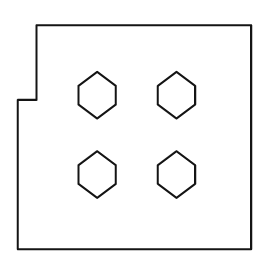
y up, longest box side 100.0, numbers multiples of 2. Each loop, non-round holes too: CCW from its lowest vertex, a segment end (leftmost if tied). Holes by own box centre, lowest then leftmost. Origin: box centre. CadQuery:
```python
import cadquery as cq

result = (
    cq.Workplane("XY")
    .moveTo(-50.0, -48.0)
    .lineTo(50.0, -48.0)
    .lineTo(50.0, 48.0)
    .lineTo(-42.0, 48.0)
    .lineTo(-42.0, 16.0)
    .lineTo(-50.0, 16.0)
    .close()
    .moveTo(-16.0, -26.0)
    .lineTo(-8.0, -20.0)
    .lineTo(-8.0, -12.0)
    .lineTo(-16.0, -6.0)
    .lineTo(-24.0, -12.0)
    .lineTo(-24.0, -20.0)
    .close()
    .moveTo(18.0, -26.0)
    .lineTo(26.0, -20.0)
    .lineTo(26.0, -12.0)
    .lineTo(18.0, -6.0)
    .lineTo(10.0, -12.0)
    .lineTo(10.0, -20.0)
    .close()
    .moveTo(-16.0, 8.0)
    .lineTo(-8.0, 14.0)
    .lineTo(-8.0, 22.0)
    .lineTo(-16.0, 28.0)
    .lineTo(-24.0, 22.0)
    .lineTo(-24.0, 14.0)
    .close()
    .moveTo(18.0, 8.0)
    .lineTo(26.0, 14.0)
    .lineTo(26.0, 22.0)
    .lineTo(18.0, 28.0)
    .lineTo(10.0, 22.0)
    .lineTo(10.0, 14.0)
    .close()
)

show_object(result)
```